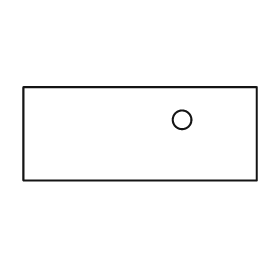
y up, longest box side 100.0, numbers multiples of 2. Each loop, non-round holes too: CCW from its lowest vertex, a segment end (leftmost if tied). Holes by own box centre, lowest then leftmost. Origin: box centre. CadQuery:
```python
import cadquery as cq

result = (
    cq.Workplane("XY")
    .moveTo(-50.0, -20.0)
    .lineTo(50.0, -20.0)
    .lineTo(50.0, 20.0)
    .lineTo(-50.0, 20.0)
    .close()
    .moveTo(18.0, 6.0)
    .circle(4.0)
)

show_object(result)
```